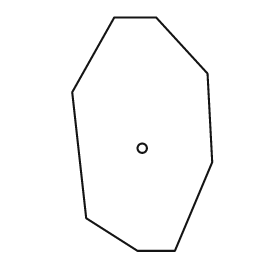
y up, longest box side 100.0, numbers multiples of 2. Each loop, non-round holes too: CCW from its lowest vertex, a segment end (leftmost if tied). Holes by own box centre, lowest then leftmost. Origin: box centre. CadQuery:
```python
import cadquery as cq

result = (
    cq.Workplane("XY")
    .moveTo(-2.0, -50.0)
    .lineTo(14.0, -50.0)
    .lineTo(30.0, -12.0)
    .lineTo(28.0, 26.0)
    .lineTo(6.0, 50.0)
    .lineTo(-12.0, 50.0)
    .lineTo(-30.0, 18.0)
    .lineTo(-24.0, -36.0)
    .close()
    .moveTo(0.0, -6.0)
    .circle(2.0)
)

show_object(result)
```